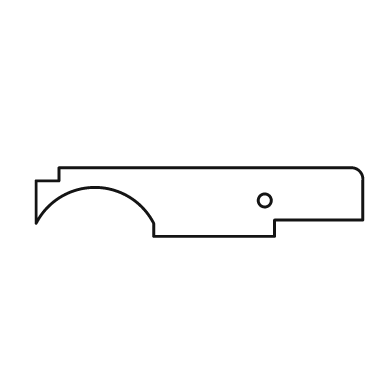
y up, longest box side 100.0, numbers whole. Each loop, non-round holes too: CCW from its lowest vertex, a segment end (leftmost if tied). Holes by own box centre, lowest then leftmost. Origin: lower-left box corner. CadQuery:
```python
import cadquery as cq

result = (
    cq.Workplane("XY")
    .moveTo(36.0, 0.0)
    .lineTo(73.0, 0.0)
    .lineTo(73.0, 5.0)
    .lineTo(100.0, 5.0)
    .lineTo(100.0, 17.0)
    .threePointArc((99.0, 20.0), (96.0, 21.0))
    .lineTo(7.0, 21.0)
    .lineTo(7.0, 17.0)
    .lineTo(0.0, 17.0)
    .lineTo(0.0, 4.0)
    .threePointArc((18.0, 15.0), (36.0, 4.0))
    .close()
    .moveTo(70.0, 11.0)
    .circle(2.0)
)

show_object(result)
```